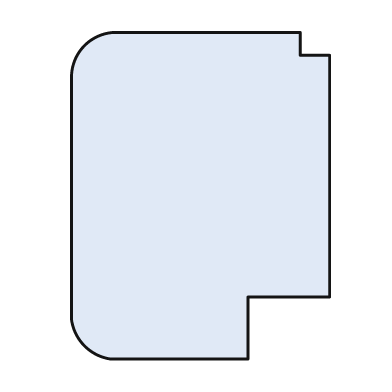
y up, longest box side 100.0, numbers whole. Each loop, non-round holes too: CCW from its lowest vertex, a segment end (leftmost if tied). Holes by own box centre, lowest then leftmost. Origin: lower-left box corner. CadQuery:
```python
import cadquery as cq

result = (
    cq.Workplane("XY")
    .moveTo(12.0, 0.0)
    .lineTo(54.0, 0.0)
    .lineTo(54.0, 19.0)
    .lineTo(79.0, 19.0)
    .lineTo(79.0, 93.0)
    .lineTo(70.0, 93.0)
    .lineTo(70.0, 100.0)
    .lineTo(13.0, 100.0)
    .threePointArc((4.0, 96.0), (0.0, 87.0))
    .lineTo(0.0, 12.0)
    .threePointArc((4.0, 4.0), (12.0, 0.0))
    .close()
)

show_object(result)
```